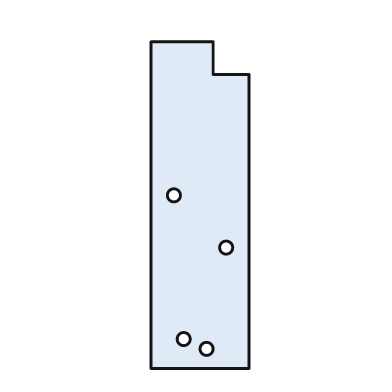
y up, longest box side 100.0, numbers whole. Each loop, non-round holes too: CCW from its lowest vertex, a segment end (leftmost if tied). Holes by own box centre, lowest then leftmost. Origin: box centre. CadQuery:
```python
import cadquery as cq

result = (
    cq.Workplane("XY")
    .moveTo(-15.0, -50.0)
    .lineTo(15.0, -50.0)
    .lineTo(15.0, 40.0)
    .lineTo(4.0, 40.0)
    .lineTo(4.0, 50.0)
    .lineTo(-15.0, 50.0)
    .close()
    .moveTo(2.0, -44.0)
    .circle(2.0)
    .moveTo(-5.0, -41.0)
    .circle(2.0)
    .moveTo(8.0, -13.0)
    .circle(2.0)
    .moveTo(-8.0, 3.0)
    .circle(2.0)
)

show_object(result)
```